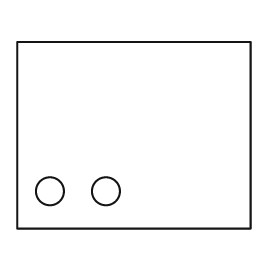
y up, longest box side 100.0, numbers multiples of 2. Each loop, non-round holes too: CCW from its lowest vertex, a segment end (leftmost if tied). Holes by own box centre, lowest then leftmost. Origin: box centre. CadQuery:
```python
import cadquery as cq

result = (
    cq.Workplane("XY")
    .moveTo(-50.0, -40.0)
    .lineTo(50.0, -40.0)
    .lineTo(50.0, 40.0)
    .lineTo(-50.0, 40.0)
    .close()
    .moveTo(-36.0, -24.0)
    .circle(6.0)
    .moveTo(-12.0, -24.0)
    .circle(6.0)
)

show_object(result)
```